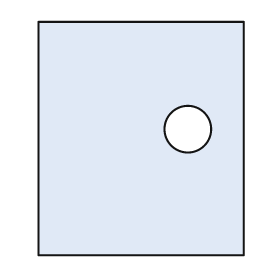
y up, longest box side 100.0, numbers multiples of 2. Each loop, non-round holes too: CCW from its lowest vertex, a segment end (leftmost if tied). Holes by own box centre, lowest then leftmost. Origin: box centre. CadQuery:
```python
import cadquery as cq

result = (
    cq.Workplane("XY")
    .moveTo(-44.0, -50.0)
    .lineTo(44.0, -50.0)
    .lineTo(44.0, 50.0)
    .lineTo(-44.0, 50.0)
    .close()
    .moveTo(20.0, 4.0)
    .circle(10.0)
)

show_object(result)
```